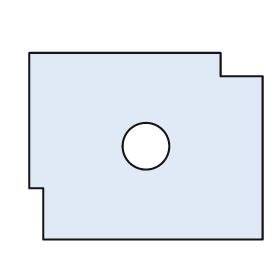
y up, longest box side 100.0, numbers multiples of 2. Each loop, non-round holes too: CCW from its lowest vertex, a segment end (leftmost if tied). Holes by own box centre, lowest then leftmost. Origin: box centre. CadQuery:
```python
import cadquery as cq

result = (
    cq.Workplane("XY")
    .moveTo(-44.0, -40.0)
    .lineTo(50.0, -40.0)
    .lineTo(50.0, 30.0)
    .lineTo(32.0, 30.0)
    .lineTo(32.0, 40.0)
    .lineTo(-50.0, 40.0)
    .lineTo(-50.0, -18.0)
    .lineTo(-44.0, -18.0)
    .close()
    .moveTo(0.0, 0.0)
    .circle(10.0)
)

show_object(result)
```